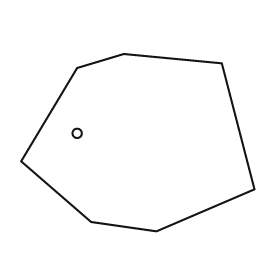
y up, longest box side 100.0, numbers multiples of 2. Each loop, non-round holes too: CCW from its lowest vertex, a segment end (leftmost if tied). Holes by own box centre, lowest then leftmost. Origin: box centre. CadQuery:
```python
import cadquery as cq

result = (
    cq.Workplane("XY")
    .moveTo(8.0, -38.0)
    .lineTo(50.0, -20.0)
    .lineTo(36.0, 34.0)
    .lineTo(-6.0, 38.0)
    .lineTo(-26.0, 32.0)
    .lineTo(-50.0, -8.0)
    .lineTo(-20.0, -34.0)
    .close()
    .moveTo(-26.0, 4.0)
    .circle(2.0)
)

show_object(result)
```